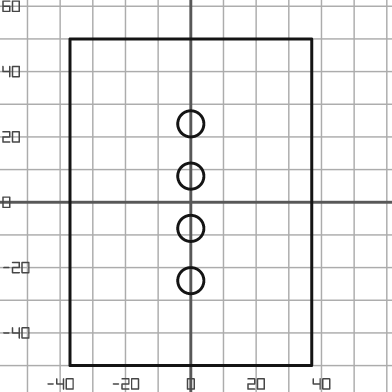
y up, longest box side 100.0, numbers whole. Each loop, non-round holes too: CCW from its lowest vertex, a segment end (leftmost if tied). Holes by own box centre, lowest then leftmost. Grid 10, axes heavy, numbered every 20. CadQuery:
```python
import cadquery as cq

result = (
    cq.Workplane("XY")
    .moveTo(-37.0, -50.0)
    .lineTo(37.0, -50.0)
    .lineTo(37.0, 50.0)
    .lineTo(-37.0, 50.0)
    .close()
    .moveTo(0.0, -24.0)
    .circle(4.0)
    .moveTo(0.0, -8.0)
    .circle(4.0)
    .moveTo(0.0, 8.0)
    .circle(4.0)
    .moveTo(0.0, 24.0)
    .circle(4.0)
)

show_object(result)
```